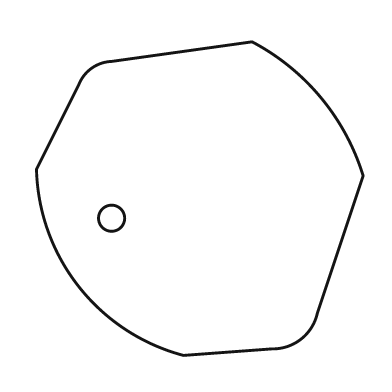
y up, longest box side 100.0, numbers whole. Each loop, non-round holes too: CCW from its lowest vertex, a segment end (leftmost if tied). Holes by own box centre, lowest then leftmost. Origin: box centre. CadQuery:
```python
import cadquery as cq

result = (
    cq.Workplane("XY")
    .moveTo(-5.0, -48.0)
    .lineTo(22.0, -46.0)
    .threePointArc((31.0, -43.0), (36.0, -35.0))
    .lineTo(50.0, 7.0)
    .threePointArc((37.0, 31.0), (16.0, 48.0))
    .lineTo(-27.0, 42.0)
    .threePointArc((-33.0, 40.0), (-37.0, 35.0))
    .lineTo(-50.0, 9.0)
    .threePointArc((-37.0, -27.0), (-5.0, -48.0))
    .close()
    .moveTo(-27.0, -6.0)
    .circle(4.0)
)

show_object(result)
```